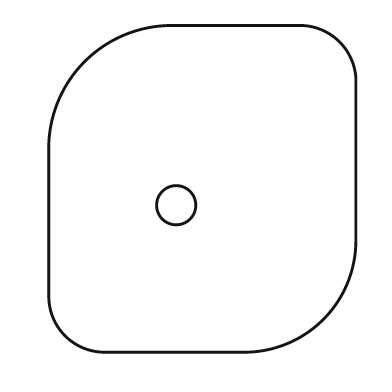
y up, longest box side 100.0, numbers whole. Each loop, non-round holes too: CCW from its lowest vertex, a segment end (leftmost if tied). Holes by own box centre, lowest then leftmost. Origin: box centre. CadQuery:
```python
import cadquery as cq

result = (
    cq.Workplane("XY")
    .moveTo(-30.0, -50.0)
    .lineTo(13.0, -50.0)
    .threePointArc((37.0, -40.0), (47.0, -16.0))
    .lineTo(47.0, 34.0)
    .threePointArc((42.0, 45.0), (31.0, 50.0))
    .lineTo(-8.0, 50.0)
    .threePointArc((-36.0, 39.0), (-47.0, 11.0))
    .lineTo(-47.0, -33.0)
    .threePointArc((-42.0, -45.0), (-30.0, -50.0))
    .close()
    .moveTo(-8.0, -5.0)
    .circle(6.0)
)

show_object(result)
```